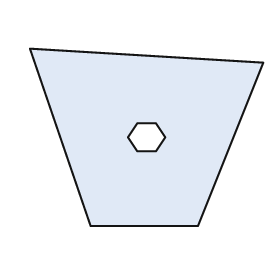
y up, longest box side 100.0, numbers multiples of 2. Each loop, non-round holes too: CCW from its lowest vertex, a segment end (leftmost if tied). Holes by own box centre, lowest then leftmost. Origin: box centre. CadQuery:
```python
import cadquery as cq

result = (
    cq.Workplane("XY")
    .moveTo(-24.0, -38.0)
    .lineTo(22.0, -38.0)
    .lineTo(50.0, 32.0)
    .lineTo(-50.0, 38.0)
    .close()
    .moveTo(-4.0, -6.0)
    .lineTo(4.0, -6.0)
    .lineTo(8.0, 0.0)
    .lineTo(4.0, 6.0)
    .lineTo(-4.0, 6.0)
    .lineTo(-8.0, 0.0)
    .close()
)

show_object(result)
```